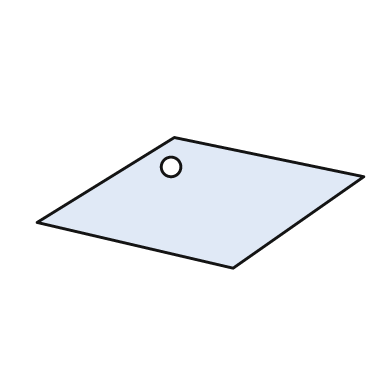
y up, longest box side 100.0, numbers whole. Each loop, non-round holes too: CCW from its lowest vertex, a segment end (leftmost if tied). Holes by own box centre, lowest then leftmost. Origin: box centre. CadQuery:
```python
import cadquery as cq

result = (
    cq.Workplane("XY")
    .moveTo(10.0, -20.0)
    .lineTo(50.0, 8.0)
    .lineTo(-8.0, 20.0)
    .lineTo(-50.0, -6.0)
    .close()
    .moveTo(-9.0, 11.0)
    .circle(3.0)
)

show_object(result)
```